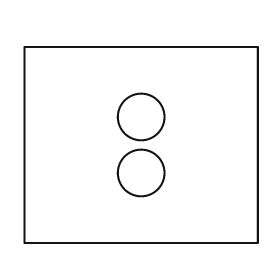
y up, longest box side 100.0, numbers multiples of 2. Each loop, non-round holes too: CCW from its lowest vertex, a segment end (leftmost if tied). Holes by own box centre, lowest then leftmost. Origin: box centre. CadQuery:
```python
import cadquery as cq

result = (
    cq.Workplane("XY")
    .moveTo(-50.0, -42.0)
    .lineTo(50.0, -42.0)
    .lineTo(50.0, 42.0)
    .lineTo(-50.0, 42.0)
    .close()
    .moveTo(0.0, -12.0)
    .circle(10.0)
    .moveTo(0.0, 12.0)
    .circle(10.0)
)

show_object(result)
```